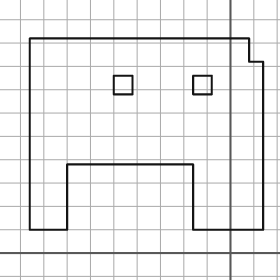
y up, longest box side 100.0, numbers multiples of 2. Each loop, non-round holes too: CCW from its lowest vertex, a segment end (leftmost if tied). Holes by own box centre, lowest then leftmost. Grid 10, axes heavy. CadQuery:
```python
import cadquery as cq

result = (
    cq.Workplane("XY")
    .moveTo(-86.0, 10.0)
    .lineTo(-70.0, 10.0)
    .lineTo(-70.0, 38.0)
    .lineTo(-16.0, 38.0)
    .lineTo(-16.0, 10.0)
    .lineTo(14.0, 10.0)
    .lineTo(14.0, 82.0)
    .lineTo(8.0, 82.0)
    .lineTo(8.0, 92.0)
    .lineTo(-86.0, 92.0)
    .close()
    .moveTo(-50.0, 68.0)
    .lineTo(-42.0, 68.0)
    .lineTo(-42.0, 76.0)
    .lineTo(-50.0, 76.0)
    .close()
    .moveTo(-16.0, 68.0)
    .lineTo(-8.0, 68.0)
    .lineTo(-8.0, 76.0)
    .lineTo(-16.0, 76.0)
    .close()
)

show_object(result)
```